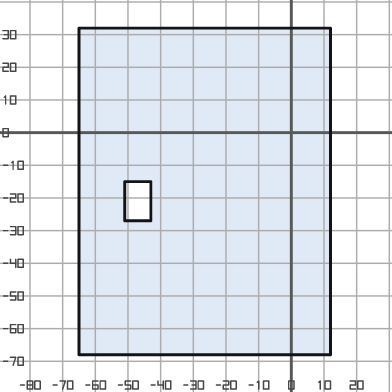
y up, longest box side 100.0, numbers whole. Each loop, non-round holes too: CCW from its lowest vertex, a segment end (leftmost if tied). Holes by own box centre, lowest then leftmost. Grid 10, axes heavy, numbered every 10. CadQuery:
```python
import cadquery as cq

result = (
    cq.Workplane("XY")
    .moveTo(-65.0, -68.0)
    .lineTo(12.0, -68.0)
    .lineTo(12.0, 32.0)
    .lineTo(-65.0, 32.0)
    .close()
    .moveTo(-51.0, -27.0)
    .lineTo(-43.0, -27.0)
    .lineTo(-43.0, -15.0)
    .lineTo(-51.0, -15.0)
    .close()
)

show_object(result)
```